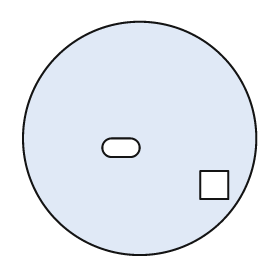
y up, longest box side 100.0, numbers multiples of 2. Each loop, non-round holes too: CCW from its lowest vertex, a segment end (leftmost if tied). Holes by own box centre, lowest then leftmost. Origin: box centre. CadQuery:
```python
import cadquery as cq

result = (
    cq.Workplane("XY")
    .moveTo(0.0, 0.0)
    .circle(50.0)
    .moveTo(26.0, -26.0)
    .lineTo(38.0, -26.0)
    .lineTo(38.0, -14.0)
    .lineTo(26.0, -14.0)
    .close()
    .moveTo(-12.0, -8.0)
    .lineTo(-4.0, -8.0)
    .threePointArc((0.0, -4.0), (-4.0, 0.0))
    .lineTo(-12.0, 0.0)
    .threePointArc((-16.0, -4.0), (-12.0, -8.0))
    .close()
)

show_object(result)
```